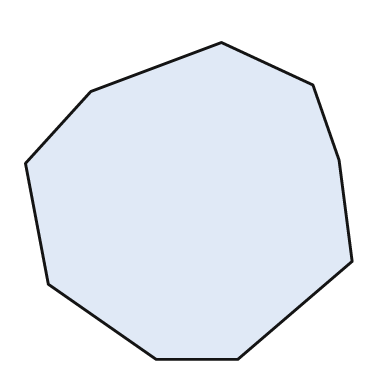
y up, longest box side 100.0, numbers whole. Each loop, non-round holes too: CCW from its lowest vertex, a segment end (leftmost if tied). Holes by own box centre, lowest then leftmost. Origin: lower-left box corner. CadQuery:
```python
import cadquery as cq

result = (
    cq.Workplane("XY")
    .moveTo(40.0, 0.0)
    .lineTo(65.0, 0.0)
    .lineTo(100.0, 30.0)
    .lineTo(96.0, 61.0)
    .lineTo(88.0, 84.0)
    .lineTo(60.0, 97.0)
    .lineTo(20.0, 82.0)
    .lineTo(0.0, 60.0)
    .lineTo(7.0, 23.0)
    .close()
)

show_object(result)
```